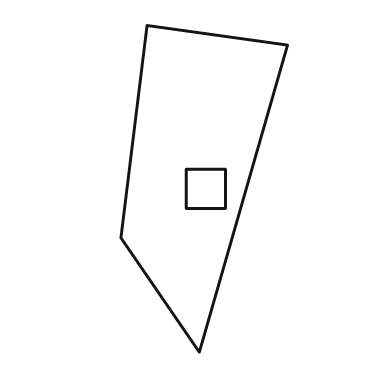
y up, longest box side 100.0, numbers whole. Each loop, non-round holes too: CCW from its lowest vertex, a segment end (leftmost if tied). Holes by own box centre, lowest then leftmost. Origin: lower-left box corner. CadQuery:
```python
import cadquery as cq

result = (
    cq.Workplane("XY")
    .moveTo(24.0, 0.0)
    .lineTo(51.0, 94.0)
    .lineTo(8.0, 100.0)
    .lineTo(0.0, 35.0)
    .close()
    .moveTo(20.0, 44.0)
    .lineTo(32.0, 44.0)
    .lineTo(32.0, 56.0)
    .lineTo(20.0, 56.0)
    .close()
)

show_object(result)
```